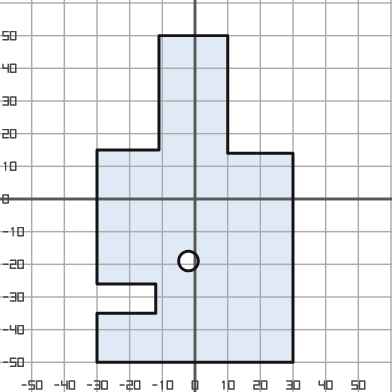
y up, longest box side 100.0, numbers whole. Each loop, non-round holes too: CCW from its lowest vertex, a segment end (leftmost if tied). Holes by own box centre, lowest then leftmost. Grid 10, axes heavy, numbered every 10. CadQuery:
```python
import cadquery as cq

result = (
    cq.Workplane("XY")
    .moveTo(-30.0, -50.0)
    .lineTo(30.0, -50.0)
    .lineTo(30.0, 14.0)
    .lineTo(10.0, 14.0)
    .lineTo(10.0, 50.0)
    .lineTo(-11.0, 50.0)
    .lineTo(-11.0, 15.0)
    .lineTo(-30.0, 15.0)
    .lineTo(-30.0, -26.0)
    .lineTo(-12.0, -26.0)
    .lineTo(-12.0, -35.0)
    .lineTo(-30.0, -35.0)
    .close()
    .moveTo(-2.0, -19.0)
    .circle(3.0)
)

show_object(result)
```